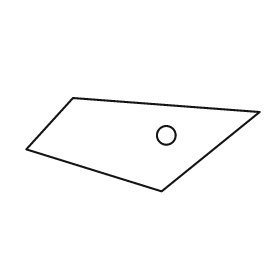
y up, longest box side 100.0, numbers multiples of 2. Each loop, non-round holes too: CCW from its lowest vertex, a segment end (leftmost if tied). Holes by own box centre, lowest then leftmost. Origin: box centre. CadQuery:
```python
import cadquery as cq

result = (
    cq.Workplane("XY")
    .moveTo(8.0, -20.0)
    .lineTo(50.0, 14.0)
    .lineTo(-30.0, 20.0)
    .lineTo(-50.0, -2.0)
    .close()
    .moveTo(10.0, 4.0)
    .circle(4.0)
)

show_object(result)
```